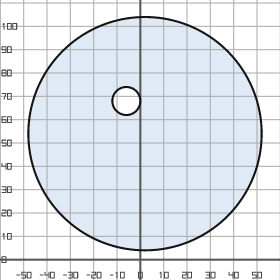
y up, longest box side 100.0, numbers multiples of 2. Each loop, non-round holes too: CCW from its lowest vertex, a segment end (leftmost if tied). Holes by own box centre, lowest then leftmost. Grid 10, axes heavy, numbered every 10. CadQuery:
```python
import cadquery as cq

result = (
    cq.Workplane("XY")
    .moveTo(2.0, 54.0)
    .circle(50.0)
    .moveTo(-6.0, 68.0)
    .circle(6.0)
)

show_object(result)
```